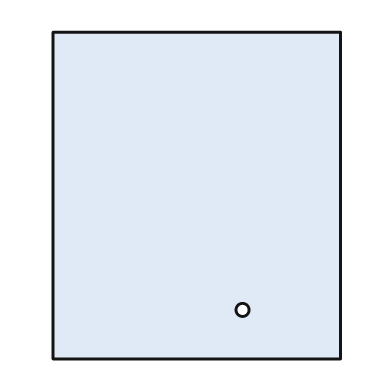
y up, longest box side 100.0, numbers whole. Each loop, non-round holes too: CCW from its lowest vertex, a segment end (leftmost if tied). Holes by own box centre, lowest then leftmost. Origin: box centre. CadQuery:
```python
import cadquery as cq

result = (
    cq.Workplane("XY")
    .moveTo(-44.0, -50.0)
    .lineTo(44.0, -50.0)
    .lineTo(44.0, 50.0)
    .lineTo(-44.0, 50.0)
    .close()
    .moveTo(14.0, -35.0)
    .circle(2.0)
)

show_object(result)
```